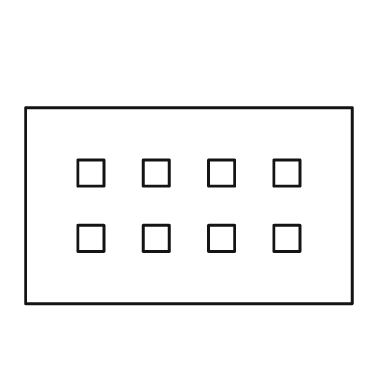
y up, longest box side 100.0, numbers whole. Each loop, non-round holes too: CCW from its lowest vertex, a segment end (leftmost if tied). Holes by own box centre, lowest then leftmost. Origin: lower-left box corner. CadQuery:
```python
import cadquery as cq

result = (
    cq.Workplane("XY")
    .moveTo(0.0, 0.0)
    .lineTo(100.0, 0.0)
    .lineTo(100.0, 60.0)
    .lineTo(0.0, 60.0)
    .close()
    .moveTo(16.0, 16.0)
    .lineTo(24.0, 16.0)
    .lineTo(24.0, 24.0)
    .lineTo(16.0, 24.0)
    .close()
    .moveTo(36.0, 16.0)
    .lineTo(44.0, 16.0)
    .lineTo(44.0, 24.0)
    .lineTo(36.0, 24.0)
    .close()
    .moveTo(56.0, 16.0)
    .lineTo(64.0, 16.0)
    .lineTo(64.0, 24.0)
    .lineTo(56.0, 24.0)
    .close()
    .moveTo(76.0, 16.0)
    .lineTo(84.0, 16.0)
    .lineTo(84.0, 24.0)
    .lineTo(76.0, 24.0)
    .close()
    .moveTo(16.0, 36.0)
    .lineTo(24.0, 36.0)
    .lineTo(24.0, 44.0)
    .lineTo(16.0, 44.0)
    .close()
    .moveTo(36.0, 36.0)
    .lineTo(44.0, 36.0)
    .lineTo(44.0, 44.0)
    .lineTo(36.0, 44.0)
    .close()
    .moveTo(56.0, 36.0)
    .lineTo(64.0, 36.0)
    .lineTo(64.0, 44.0)
    .lineTo(56.0, 44.0)
    .close()
    .moveTo(76.0, 36.0)
    .lineTo(84.0, 36.0)
    .lineTo(84.0, 44.0)
    .lineTo(76.0, 44.0)
    .close()
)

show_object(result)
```